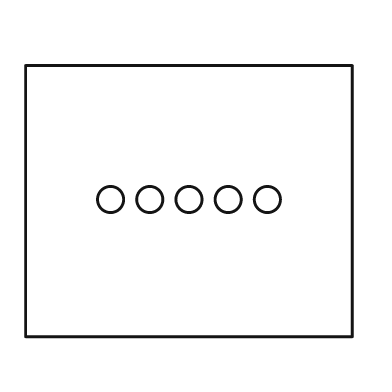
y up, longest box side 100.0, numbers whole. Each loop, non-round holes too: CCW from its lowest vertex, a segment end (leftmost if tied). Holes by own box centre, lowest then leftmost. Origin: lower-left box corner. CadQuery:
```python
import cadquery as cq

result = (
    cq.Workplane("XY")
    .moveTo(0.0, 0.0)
    .lineTo(100.0, 0.0)
    .lineTo(100.0, 83.0)
    .lineTo(0.0, 83.0)
    .close()
    .moveTo(26.0, 42.0)
    .circle(4.0)
    .moveTo(38.0, 42.0)
    .circle(4.0)
    .moveTo(50.0, 42.0)
    .circle(4.0)
    .moveTo(62.0, 42.0)
    .circle(4.0)
    .moveTo(74.0, 42.0)
    .circle(4.0)
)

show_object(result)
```